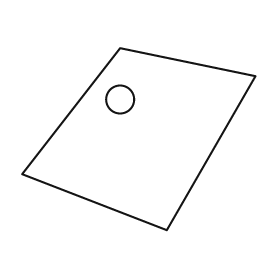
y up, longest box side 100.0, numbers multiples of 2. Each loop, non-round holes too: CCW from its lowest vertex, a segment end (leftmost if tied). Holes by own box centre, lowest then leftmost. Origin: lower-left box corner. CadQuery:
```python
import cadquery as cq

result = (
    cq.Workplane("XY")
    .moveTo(62.0, 0.0)
    .lineTo(100.0, 66.0)
    .lineTo(42.0, 78.0)
    .lineTo(0.0, 24.0)
    .close()
    .moveTo(42.0, 56.0)
    .circle(6.0)
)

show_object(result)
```